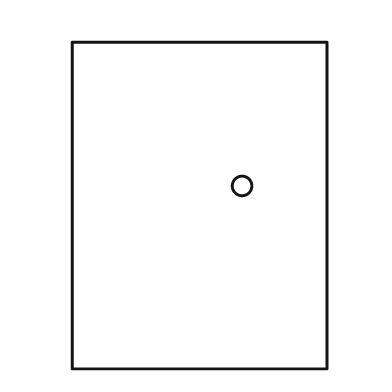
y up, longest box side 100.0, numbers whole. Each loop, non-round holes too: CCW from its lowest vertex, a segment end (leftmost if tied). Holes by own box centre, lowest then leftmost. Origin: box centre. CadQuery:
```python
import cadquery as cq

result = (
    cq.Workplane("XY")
    .moveTo(-39.0, -50.0)
    .lineTo(39.0, -50.0)
    .lineTo(39.0, 50.0)
    .lineTo(-39.0, 50.0)
    .close()
    .moveTo(13.0, 6.0)
    .circle(3.0)
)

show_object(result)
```